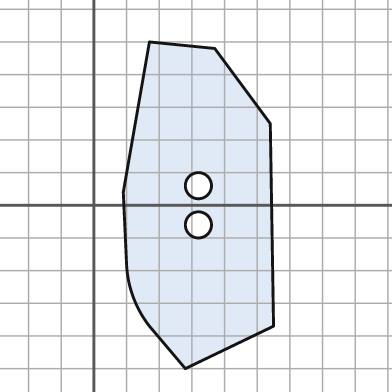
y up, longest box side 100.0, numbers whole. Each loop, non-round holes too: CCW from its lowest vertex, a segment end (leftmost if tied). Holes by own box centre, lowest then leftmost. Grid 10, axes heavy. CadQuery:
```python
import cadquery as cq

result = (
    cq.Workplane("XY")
    .moveTo(28.0, -50.0)
    .lineTo(55.0, -37.0)
    .lineTo(54.0, 25.0)
    .lineTo(37.0, 48.0)
    .lineTo(17.0, 50.0)
    .lineTo(9.0, 4.0)
    .lineTo(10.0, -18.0)
    .threePointArc((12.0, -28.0), (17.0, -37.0))
    .close()
    .moveTo(32.0, -6.0)
    .circle(4.0)
    .moveTo(32.0, 6.0)
    .circle(4.0)
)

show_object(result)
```